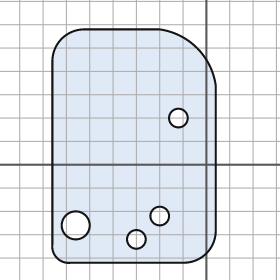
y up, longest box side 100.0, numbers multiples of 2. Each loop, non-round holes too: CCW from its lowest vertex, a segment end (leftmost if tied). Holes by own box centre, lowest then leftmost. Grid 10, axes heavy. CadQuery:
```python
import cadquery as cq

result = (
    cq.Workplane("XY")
    .moveTo(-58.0, -42.0)
    .lineTo(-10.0, -42.0)
    .threePointArc((0.0, -38.0), (4.0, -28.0))
    .lineTo(4.0, 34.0)
    .threePointArc((-4.0, 50.0), (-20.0, 58.0))
    .lineTo(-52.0, 58.0)
    .threePointArc((-62.0, 54.0), (-66.0, 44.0))
    .lineTo(-66.0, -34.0)
    .threePointArc((-64.0, -40.0), (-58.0, -42.0))
    .close()
    .moveTo(-30.0, -32.0)
    .circle(4.0)
    .moveTo(-56.0, -26.0)
    .circle(6.0)
    .moveTo(-20.0, -22.0)
    .circle(4.0)
    .moveTo(-12.0, 20.0)
    .circle(4.0)
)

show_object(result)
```